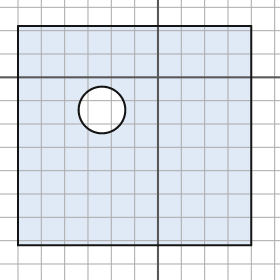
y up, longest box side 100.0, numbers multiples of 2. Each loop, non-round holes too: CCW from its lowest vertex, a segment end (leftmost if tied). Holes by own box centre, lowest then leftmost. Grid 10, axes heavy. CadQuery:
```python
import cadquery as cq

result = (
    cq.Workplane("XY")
    .moveTo(-60.0, -72.0)
    .lineTo(40.0, -72.0)
    .lineTo(40.0, 22.0)
    .lineTo(-60.0, 22.0)
    .close()
    .moveTo(-24.0, -14.0)
    .circle(10.0)
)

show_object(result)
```